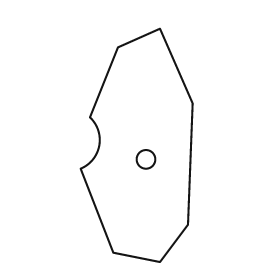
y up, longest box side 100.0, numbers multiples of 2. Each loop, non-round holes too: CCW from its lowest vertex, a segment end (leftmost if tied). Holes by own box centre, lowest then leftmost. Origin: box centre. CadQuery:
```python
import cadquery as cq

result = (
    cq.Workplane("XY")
    .moveTo(10.0, -50.0)
    .lineTo(22.0, -34.0)
    .lineTo(24.0, 18.0)
    .lineTo(10.0, 50.0)
    .lineTo(-8.0, 42.0)
    .lineTo(-20.0, 12.0)
    .threePointArc((-16.0, 0.0), (-24.0, -10.0))
    .lineTo(-10.0, -46.0)
    .close()
    .moveTo(4.0, -6.0)
    .circle(4.0)
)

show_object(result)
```